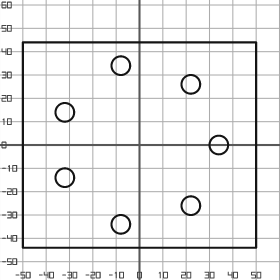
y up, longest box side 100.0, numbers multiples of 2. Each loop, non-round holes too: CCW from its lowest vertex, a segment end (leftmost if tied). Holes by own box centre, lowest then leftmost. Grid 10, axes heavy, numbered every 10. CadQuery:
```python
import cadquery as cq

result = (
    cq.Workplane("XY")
    .moveTo(-50.0, -44.0)
    .lineTo(50.0, -44.0)
    .lineTo(50.0, 44.0)
    .lineTo(-50.0, 44.0)
    .close()
    .moveTo(-8.0, -34.0)
    .circle(4.0)
    .moveTo(22.0, -26.0)
    .circle(4.0)
    .moveTo(-32.0, -14.0)
    .circle(4.0)
    .moveTo(34.0, 0.0)
    .circle(4.0)
    .moveTo(-32.0, 14.0)
    .circle(4.0)
    .moveTo(22.0, 26.0)
    .circle(4.0)
    .moveTo(-8.0, 34.0)
    .circle(4.0)
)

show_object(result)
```